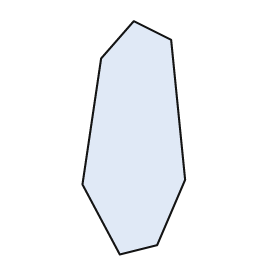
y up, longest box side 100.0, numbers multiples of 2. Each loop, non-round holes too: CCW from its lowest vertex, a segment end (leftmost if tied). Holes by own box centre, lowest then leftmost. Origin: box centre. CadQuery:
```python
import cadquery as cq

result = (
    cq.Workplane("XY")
    .moveTo(-6.0, -50.0)
    .lineTo(10.0, -46.0)
    .lineTo(22.0, -18.0)
    .lineTo(16.0, 42.0)
    .lineTo(0.0, 50.0)
    .lineTo(-14.0, 34.0)
    .lineTo(-22.0, -20.0)
    .close()
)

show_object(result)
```